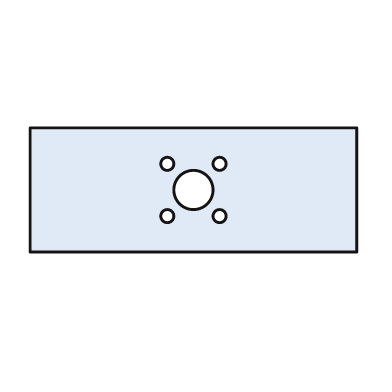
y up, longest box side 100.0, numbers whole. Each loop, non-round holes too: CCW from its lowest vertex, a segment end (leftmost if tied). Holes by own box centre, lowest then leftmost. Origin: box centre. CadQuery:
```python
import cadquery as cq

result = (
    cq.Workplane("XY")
    .moveTo(-50.0, -19.0)
    .lineTo(50.0, -19.0)
    .lineTo(50.0, 19.0)
    .lineTo(-50.0, 19.0)
    .close()
    .moveTo(-8.0, -8.0)
    .circle(2.0)
    .moveTo(8.0, -8.0)
    .circle(2.0)
    .moveTo(0.0, 0.0)
    .circle(6.0)
    .moveTo(-8.0, 8.0)
    .circle(2.0)
    .moveTo(8.0, 8.0)
    .circle(2.0)
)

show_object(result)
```